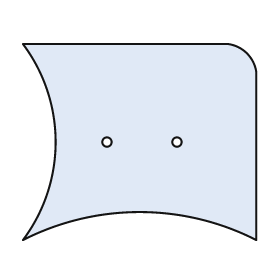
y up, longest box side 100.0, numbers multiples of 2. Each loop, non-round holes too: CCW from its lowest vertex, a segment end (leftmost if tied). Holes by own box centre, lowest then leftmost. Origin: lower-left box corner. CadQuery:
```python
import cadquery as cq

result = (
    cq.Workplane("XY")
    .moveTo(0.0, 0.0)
    .threePointArc((50.0, 12.0), (100.0, 0.0))
    .lineTo(100.0, 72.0)
    .threePointArc((96.0, 80.0), (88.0, 84.0))
    .lineTo(0.0, 84.0)
    .threePointArc((14.0, 42.0), (0.0, 0.0))
    .close()
    .moveTo(36.0, 42.0)
    .circle(2.0)
    .moveTo(66.0, 42.0)
    .circle(2.0)
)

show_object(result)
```